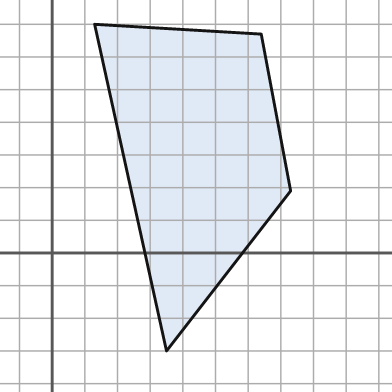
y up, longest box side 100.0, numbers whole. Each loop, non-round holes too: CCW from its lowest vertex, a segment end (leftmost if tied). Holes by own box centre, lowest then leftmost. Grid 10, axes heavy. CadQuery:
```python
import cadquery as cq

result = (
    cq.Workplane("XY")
    .moveTo(35.0, -30.0)
    .lineTo(73.0, 19.0)
    .lineTo(64.0, 67.0)
    .lineTo(13.0, 70.0)
    .close()
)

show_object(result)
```